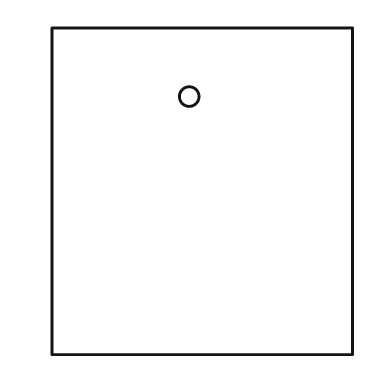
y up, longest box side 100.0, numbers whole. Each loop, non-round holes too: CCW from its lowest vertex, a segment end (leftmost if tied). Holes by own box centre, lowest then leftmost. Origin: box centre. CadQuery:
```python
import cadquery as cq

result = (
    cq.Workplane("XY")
    .moveTo(-46.0, -50.0)
    .lineTo(46.0, -50.0)
    .lineTo(46.0, 50.0)
    .lineTo(-46.0, 50.0)
    .close()
    .moveTo(-4.0, 29.0)
    .circle(3.0)
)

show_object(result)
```